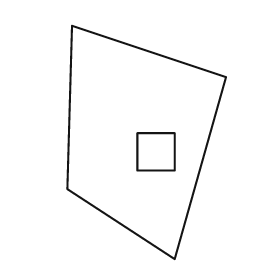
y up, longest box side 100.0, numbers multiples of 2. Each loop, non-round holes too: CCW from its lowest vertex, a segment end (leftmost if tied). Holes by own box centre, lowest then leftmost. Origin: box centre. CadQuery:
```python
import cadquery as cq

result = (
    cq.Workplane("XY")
    .moveTo(12.0, -50.0)
    .lineTo(34.0, 28.0)
    .lineTo(-32.0, 50.0)
    .lineTo(-34.0, -20.0)
    .close()
    .moveTo(-4.0, -12.0)
    .lineTo(12.0, -12.0)
    .lineTo(12.0, 4.0)
    .lineTo(-4.0, 4.0)
    .close()
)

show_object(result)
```